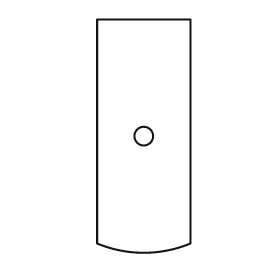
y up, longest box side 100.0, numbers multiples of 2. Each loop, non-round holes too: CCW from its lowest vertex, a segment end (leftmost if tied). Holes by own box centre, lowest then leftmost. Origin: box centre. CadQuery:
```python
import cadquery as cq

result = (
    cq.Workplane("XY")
    .moveTo(-20.0, -46.0)
    .threePointArc((0.0, -50.0), (20.0, -46.0))
    .lineTo(20.0, 50.0)
    .lineTo(-20.0, 50.0)
    .close()
    .moveTo(0.0, 0.0)
    .circle(4.0)
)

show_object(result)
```